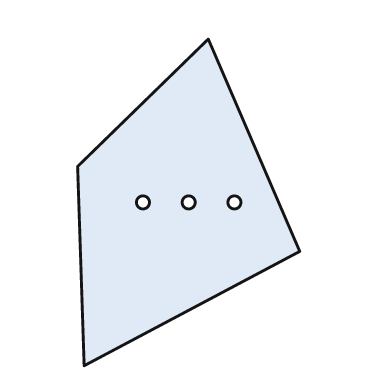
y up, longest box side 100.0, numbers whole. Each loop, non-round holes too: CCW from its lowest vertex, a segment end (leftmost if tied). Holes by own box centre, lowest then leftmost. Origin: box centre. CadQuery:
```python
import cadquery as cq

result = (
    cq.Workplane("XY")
    .moveTo(-32.0, -50.0)
    .lineTo(34.0, -15.0)
    .lineTo(6.0, 50.0)
    .lineTo(-34.0, 11.0)
    .close()
    .moveTo(-14.0, 0.0)
    .circle(2.0)
    .moveTo(0.0, 0.0)
    .circle(2.0)
    .moveTo(14.0, 0.0)
    .circle(2.0)
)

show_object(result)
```